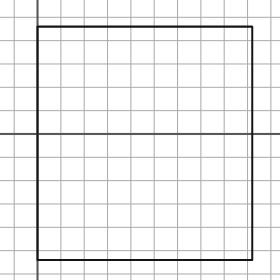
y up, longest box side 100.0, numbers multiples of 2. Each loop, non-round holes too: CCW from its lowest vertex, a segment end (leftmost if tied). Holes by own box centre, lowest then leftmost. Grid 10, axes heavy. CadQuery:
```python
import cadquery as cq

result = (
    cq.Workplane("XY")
    .moveTo(0.0, -54.0)
    .lineTo(92.0, -54.0)
    .lineTo(92.0, 46.0)
    .lineTo(0.0, 46.0)
    .close()
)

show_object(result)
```